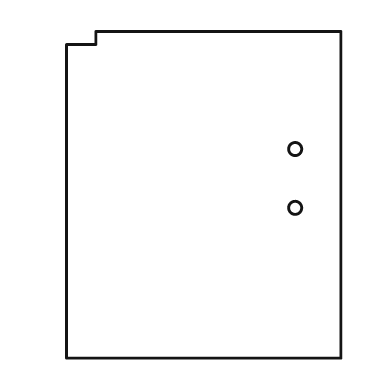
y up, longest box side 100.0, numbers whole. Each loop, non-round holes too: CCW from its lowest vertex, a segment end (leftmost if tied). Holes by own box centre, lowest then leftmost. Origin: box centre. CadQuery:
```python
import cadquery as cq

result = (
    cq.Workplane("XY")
    .moveTo(-42.0, -50.0)
    .lineTo(42.0, -50.0)
    .lineTo(42.0, 50.0)
    .lineTo(-33.0, 50.0)
    .lineTo(-33.0, 46.0)
    .lineTo(-42.0, 46.0)
    .close()
    .moveTo(28.0, -4.0)
    .circle(2.0)
    .moveTo(28.0, 14.0)
    .circle(2.0)
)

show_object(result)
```